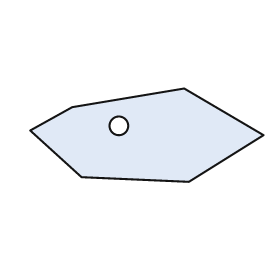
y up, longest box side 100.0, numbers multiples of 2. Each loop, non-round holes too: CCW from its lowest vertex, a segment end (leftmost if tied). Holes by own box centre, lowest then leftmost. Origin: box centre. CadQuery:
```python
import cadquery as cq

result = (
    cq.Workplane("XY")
    .moveTo(18.0, -20.0)
    .lineTo(50.0, 0.0)
    .lineTo(16.0, 20.0)
    .lineTo(-32.0, 12.0)
    .lineTo(-50.0, 2.0)
    .lineTo(-28.0, -18.0)
    .close()
    .moveTo(-12.0, 4.0)
    .circle(4.0)
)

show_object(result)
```